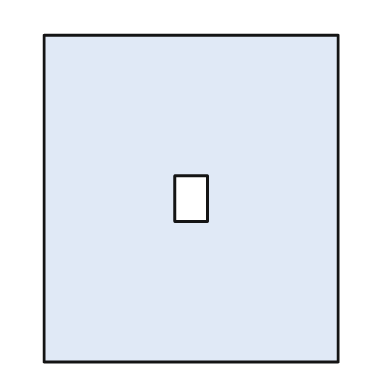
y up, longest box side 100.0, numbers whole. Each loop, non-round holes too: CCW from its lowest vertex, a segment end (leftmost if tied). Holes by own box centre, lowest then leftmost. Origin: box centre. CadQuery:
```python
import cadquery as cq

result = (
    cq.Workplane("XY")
    .moveTo(-45.0, -50.0)
    .lineTo(45.0, -50.0)
    .lineTo(45.0, 50.0)
    .lineTo(-45.0, 50.0)
    .close()
    .moveTo(-5.0, -7.0)
    .lineTo(5.0, -7.0)
    .lineTo(5.0, 7.0)
    .lineTo(-5.0, 7.0)
    .close()
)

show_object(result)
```